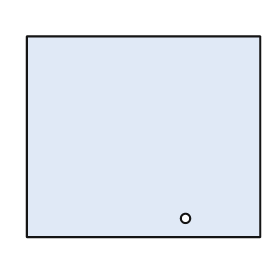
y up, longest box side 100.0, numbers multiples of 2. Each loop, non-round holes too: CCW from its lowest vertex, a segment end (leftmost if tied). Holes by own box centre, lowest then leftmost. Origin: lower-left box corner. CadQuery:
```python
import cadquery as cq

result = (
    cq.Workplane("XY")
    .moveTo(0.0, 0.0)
    .lineTo(100.0, 0.0)
    .lineTo(100.0, 86.0)
    .lineTo(0.0, 86.0)
    .close()
    .moveTo(68.0, 8.0)
    .circle(2.0)
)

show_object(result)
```